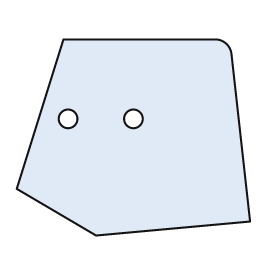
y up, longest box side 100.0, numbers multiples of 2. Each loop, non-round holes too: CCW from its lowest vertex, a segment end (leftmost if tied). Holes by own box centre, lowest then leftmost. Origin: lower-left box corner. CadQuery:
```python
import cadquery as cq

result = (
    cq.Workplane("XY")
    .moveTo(34.0, 0.0)
    .lineTo(100.0, 6.0)
    .lineTo(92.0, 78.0)
    .threePointArc((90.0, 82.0), (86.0, 84.0))
    .lineTo(20.0, 84.0)
    .lineTo(0.0, 20.0)
    .close()
    .moveTo(22.0, 50.0)
    .circle(4.0)
    .moveTo(50.0, 50.0)
    .circle(4.0)
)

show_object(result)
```